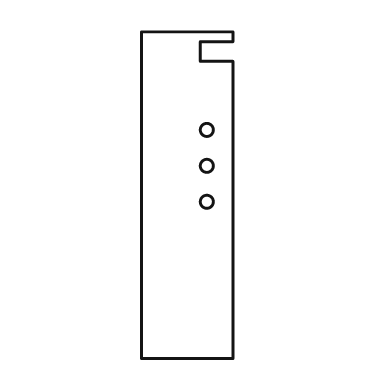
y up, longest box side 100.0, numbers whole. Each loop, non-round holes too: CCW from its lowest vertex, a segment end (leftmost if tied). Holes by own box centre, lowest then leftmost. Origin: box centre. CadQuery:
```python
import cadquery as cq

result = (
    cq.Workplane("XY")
    .moveTo(-14.0, -50.0)
    .lineTo(14.0, -50.0)
    .lineTo(14.0, 41.0)
    .lineTo(4.0, 41.0)
    .lineTo(4.0, 47.0)
    .lineTo(14.0, 47.0)
    .lineTo(14.0, 50.0)
    .lineTo(-14.0, 50.0)
    .close()
    .moveTo(6.0, -2.0)
    .circle(2.0)
    .moveTo(6.0, 9.0)
    .circle(2.0)
    .moveTo(6.0, 20.0)
    .circle(2.0)
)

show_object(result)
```